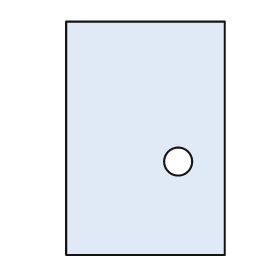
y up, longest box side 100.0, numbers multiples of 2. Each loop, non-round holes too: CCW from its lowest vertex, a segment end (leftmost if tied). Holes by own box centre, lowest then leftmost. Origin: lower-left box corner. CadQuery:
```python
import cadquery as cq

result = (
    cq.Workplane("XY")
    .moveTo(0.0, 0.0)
    .lineTo(68.0, 0.0)
    .lineTo(68.0, 100.0)
    .lineTo(0.0, 100.0)
    .close()
    .moveTo(48.0, 40.0)
    .circle(6.0)
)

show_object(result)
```